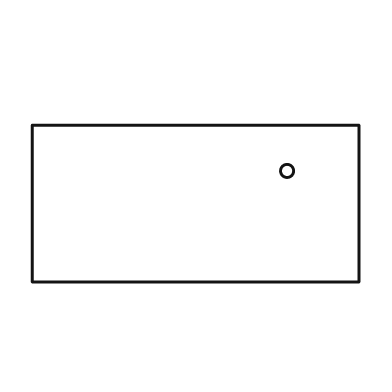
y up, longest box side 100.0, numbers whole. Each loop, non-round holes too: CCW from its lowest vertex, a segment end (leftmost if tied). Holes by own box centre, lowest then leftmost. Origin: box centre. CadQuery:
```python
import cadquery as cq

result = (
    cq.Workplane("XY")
    .moveTo(-50.0, -24.0)
    .lineTo(50.0, -24.0)
    .lineTo(50.0, 24.0)
    .lineTo(-50.0, 24.0)
    .close()
    .moveTo(28.0, 10.0)
    .circle(2.0)
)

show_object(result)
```